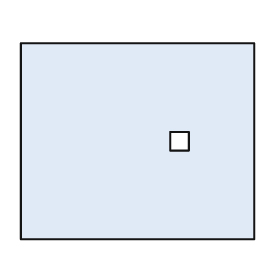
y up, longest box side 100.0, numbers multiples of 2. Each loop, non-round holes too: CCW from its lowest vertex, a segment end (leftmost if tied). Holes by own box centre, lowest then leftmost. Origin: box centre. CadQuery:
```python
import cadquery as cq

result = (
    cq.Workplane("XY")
    .moveTo(-50.0, -42.0)
    .lineTo(50.0, -42.0)
    .lineTo(50.0, 42.0)
    .lineTo(-50.0, 42.0)
    .close()
    .moveTo(14.0, -4.0)
    .lineTo(22.0, -4.0)
    .lineTo(22.0, 4.0)
    .lineTo(14.0, 4.0)
    .close()
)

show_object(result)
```